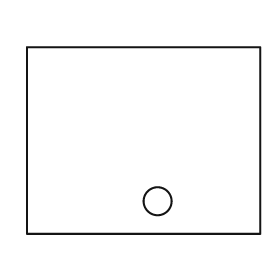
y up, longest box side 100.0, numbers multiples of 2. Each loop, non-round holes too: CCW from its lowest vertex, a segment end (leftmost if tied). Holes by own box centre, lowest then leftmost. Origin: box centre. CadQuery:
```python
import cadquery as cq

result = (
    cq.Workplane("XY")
    .moveTo(-50.0, -40.0)
    .lineTo(50.0, -40.0)
    .lineTo(50.0, 40.0)
    .lineTo(-50.0, 40.0)
    .close()
    .moveTo(6.0, -26.0)
    .circle(6.0)
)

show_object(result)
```